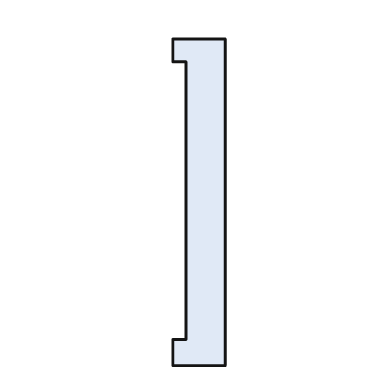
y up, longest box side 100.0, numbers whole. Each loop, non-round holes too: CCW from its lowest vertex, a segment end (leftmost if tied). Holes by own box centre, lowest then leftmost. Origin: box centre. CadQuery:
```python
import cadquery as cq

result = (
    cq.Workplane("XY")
    .moveTo(-8.0, -50.0)
    .lineTo(8.0, -50.0)
    .lineTo(8.0, 50.0)
    .lineTo(-8.0, 50.0)
    .lineTo(-8.0, 43.0)
    .lineTo(-4.0, 43.0)
    .lineTo(-4.0, -42.0)
    .lineTo(-8.0, -42.0)
    .close()
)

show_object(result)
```